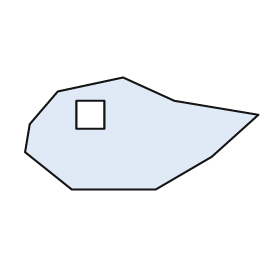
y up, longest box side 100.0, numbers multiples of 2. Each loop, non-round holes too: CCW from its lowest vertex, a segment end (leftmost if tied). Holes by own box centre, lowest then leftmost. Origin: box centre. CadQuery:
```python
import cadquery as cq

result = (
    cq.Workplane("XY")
    .moveTo(-30.0, -24.0)
    .lineTo(6.0, -24.0)
    .lineTo(30.0, -10.0)
    .lineTo(50.0, 8.0)
    .lineTo(14.0, 14.0)
    .lineTo(-8.0, 24.0)
    .lineTo(-36.0, 18.0)
    .lineTo(-48.0, 4.0)
    .lineTo(-50.0, -8.0)
    .close()
    .moveTo(-28.0, 2.0)
    .lineTo(-16.0, 2.0)
    .lineTo(-16.0, 14.0)
    .lineTo(-28.0, 14.0)
    .close()
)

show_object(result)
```